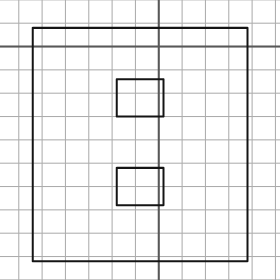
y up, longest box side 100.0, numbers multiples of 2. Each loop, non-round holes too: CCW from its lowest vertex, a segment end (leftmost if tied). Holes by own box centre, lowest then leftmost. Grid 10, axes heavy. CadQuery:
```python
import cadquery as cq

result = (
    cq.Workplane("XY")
    .moveTo(-54.0, -92.0)
    .lineTo(38.0, -92.0)
    .lineTo(38.0, 8.0)
    .lineTo(-54.0, 8.0)
    .close()
    .moveTo(-18.0, -68.0)
    .lineTo(2.0, -68.0)
    .lineTo(2.0, -52.0)
    .lineTo(-18.0, -52.0)
    .close()
    .moveTo(-18.0, -30.0)
    .lineTo(2.0, -30.0)
    .lineTo(2.0, -14.0)
    .lineTo(-18.0, -14.0)
    .close()
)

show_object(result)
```